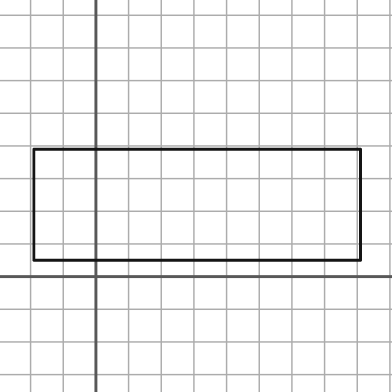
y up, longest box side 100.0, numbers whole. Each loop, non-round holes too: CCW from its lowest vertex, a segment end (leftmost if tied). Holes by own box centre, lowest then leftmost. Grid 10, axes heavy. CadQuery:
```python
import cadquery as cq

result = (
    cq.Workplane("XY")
    .moveTo(-19.0, 5.0)
    .lineTo(81.0, 5.0)
    .lineTo(81.0, 39.0)
    .lineTo(-19.0, 39.0)
    .close()
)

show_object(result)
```